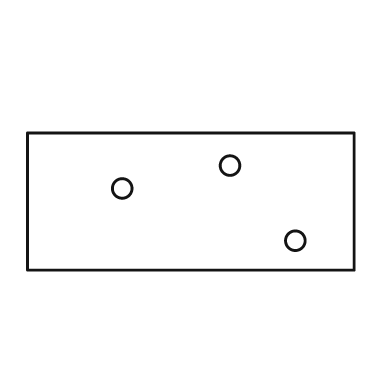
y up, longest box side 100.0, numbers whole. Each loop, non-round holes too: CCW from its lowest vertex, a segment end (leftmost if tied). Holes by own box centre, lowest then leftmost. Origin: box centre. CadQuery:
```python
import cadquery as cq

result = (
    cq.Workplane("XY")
    .moveTo(-50.0, -21.0)
    .lineTo(50.0, -21.0)
    .lineTo(50.0, 21.0)
    .lineTo(-50.0, 21.0)
    .close()
    .moveTo(32.0, -12.0)
    .circle(3.0)
    .moveTo(-21.0, 4.0)
    .circle(3.0)
    .moveTo(12.0, 11.0)
    .circle(3.0)
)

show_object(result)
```